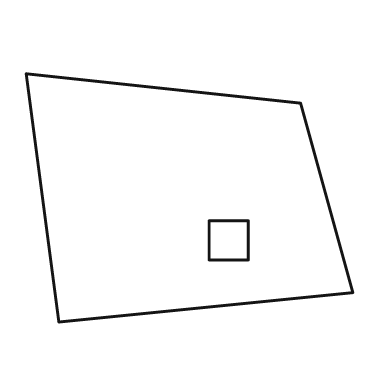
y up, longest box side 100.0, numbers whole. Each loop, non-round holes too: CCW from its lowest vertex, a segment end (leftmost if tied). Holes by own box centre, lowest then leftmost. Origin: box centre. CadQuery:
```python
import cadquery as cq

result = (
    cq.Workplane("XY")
    .moveTo(-40.0, -38.0)
    .lineTo(50.0, -29.0)
    .lineTo(34.0, 29.0)
    .lineTo(-50.0, 38.0)
    .close()
    .moveTo(6.0, -19.0)
    .lineTo(18.0, -19.0)
    .lineTo(18.0, -7.0)
    .lineTo(6.0, -7.0)
    .close()
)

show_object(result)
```